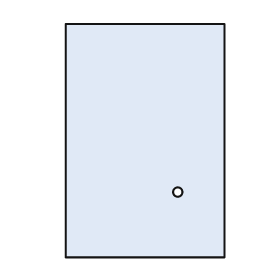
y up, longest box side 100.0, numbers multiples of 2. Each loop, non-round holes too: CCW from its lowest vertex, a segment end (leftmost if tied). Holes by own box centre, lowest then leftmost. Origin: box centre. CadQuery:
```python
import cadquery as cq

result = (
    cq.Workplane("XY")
    .moveTo(-34.0, -50.0)
    .lineTo(34.0, -50.0)
    .lineTo(34.0, 50.0)
    .lineTo(-34.0, 50.0)
    .close()
    .moveTo(14.0, -22.0)
    .circle(2.0)
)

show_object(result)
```